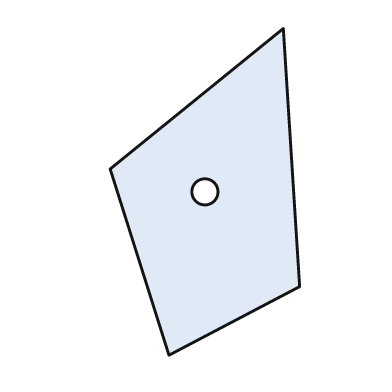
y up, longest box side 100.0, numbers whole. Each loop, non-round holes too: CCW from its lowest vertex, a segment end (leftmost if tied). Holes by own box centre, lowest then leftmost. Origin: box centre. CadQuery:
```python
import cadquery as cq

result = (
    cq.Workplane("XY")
    .moveTo(-11.0, -50.0)
    .lineTo(29.0, -29.0)
    .lineTo(24.0, 50.0)
    .lineTo(-29.0, 7.0)
    .close()
    .moveTo(0.0, 0.0)
    .circle(4.0)
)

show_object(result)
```